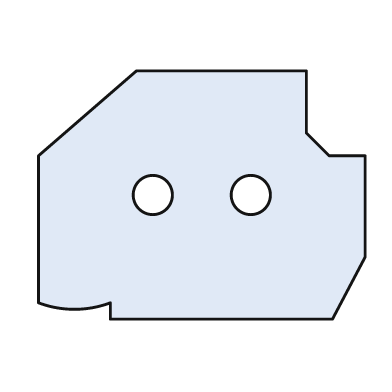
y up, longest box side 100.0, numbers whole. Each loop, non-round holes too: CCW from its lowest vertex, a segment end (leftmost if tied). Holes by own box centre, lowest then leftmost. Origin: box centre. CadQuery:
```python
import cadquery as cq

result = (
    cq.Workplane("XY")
    .moveTo(-28.0, -38.0)
    .lineTo(40.0, -38.0)
    .lineTo(50.0, -19.0)
    .lineTo(50.0, 12.0)
    .lineTo(39.0, 12.0)
    .lineTo(32.0, 19.0)
    .lineTo(32.0, 38.0)
    .lineTo(-20.0, 38.0)
    .lineTo(-50.0, 12.0)
    .lineTo(-50.0, -33.0)
    .threePointArc((-39.0, -35.0), (-28.0, -33.0))
    .close()
    .moveTo(-15.0, 0.0)
    .circle(6.0)
    .moveTo(15.0, 0.0)
    .circle(6.0)
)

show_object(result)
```